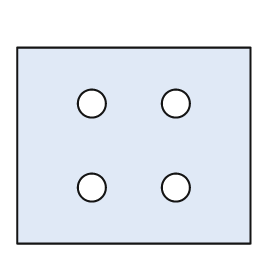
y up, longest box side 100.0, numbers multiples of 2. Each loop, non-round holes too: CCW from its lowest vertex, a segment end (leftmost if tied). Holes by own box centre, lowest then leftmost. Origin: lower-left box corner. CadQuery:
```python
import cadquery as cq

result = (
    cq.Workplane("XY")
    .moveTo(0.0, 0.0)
    .lineTo(100.0, 0.0)
    .lineTo(100.0, 84.0)
    .lineTo(0.0, 84.0)
    .close()
    .moveTo(32.0, 24.0)
    .circle(6.0)
    .moveTo(68.0, 24.0)
    .circle(6.0)
    .moveTo(32.0, 60.0)
    .circle(6.0)
    .moveTo(68.0, 60.0)
    .circle(6.0)
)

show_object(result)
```